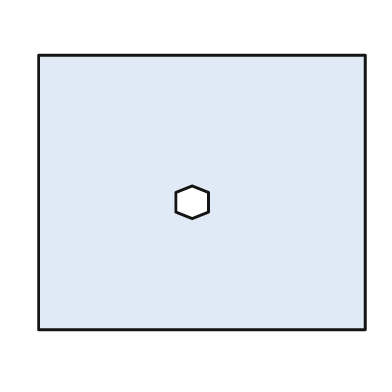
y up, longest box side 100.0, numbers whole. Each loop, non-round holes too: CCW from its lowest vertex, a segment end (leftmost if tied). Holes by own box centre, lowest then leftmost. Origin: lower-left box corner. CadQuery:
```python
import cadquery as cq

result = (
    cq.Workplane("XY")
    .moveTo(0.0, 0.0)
    .lineTo(100.0, 0.0)
    .lineTo(100.0, 84.0)
    .lineTo(0.0, 84.0)
    .close()
    .moveTo(47.0, 34.0)
    .lineTo(52.0, 36.0)
    .lineTo(52.0, 42.0)
    .lineTo(47.0, 44.0)
    .lineTo(42.0, 42.0)
    .lineTo(42.0, 36.0)
    .close()
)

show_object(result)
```